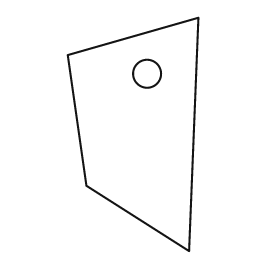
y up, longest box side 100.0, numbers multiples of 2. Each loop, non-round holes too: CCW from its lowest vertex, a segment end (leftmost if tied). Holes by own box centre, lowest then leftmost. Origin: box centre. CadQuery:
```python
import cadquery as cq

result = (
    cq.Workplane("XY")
    .moveTo(24.0, -50.0)
    .lineTo(28.0, 50.0)
    .lineTo(-28.0, 34.0)
    .lineTo(-20.0, -22.0)
    .close()
    .moveTo(6.0, 26.0)
    .circle(6.0)
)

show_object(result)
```